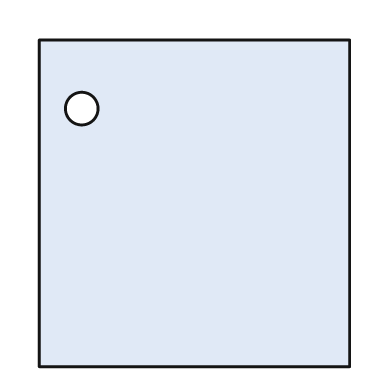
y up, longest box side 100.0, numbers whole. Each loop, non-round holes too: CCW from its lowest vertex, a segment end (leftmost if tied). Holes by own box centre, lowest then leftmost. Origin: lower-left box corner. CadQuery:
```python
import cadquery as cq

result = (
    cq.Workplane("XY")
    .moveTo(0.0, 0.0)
    .lineTo(95.0, 0.0)
    .lineTo(95.0, 100.0)
    .lineTo(0.0, 100.0)
    .close()
    .moveTo(13.0, 79.0)
    .circle(5.0)
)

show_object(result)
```